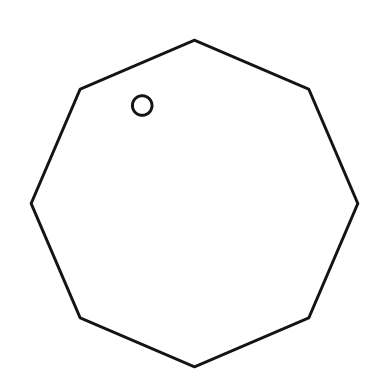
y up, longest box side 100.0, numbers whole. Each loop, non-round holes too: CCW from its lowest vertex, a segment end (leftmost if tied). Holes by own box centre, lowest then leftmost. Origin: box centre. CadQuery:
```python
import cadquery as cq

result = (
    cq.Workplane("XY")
    .moveTo(0.0, -50.0)
    .lineTo(35.0, -35.0)
    .lineTo(50.0, 0.0)
    .lineTo(35.0, 35.0)
    .lineTo(0.0, 50.0)
    .lineTo(-35.0, 35.0)
    .lineTo(-50.0, 0.0)
    .lineTo(-35.0, -35.0)
    .close()
    .moveTo(-16.0, 30.0)
    .circle(3.0)
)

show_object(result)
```